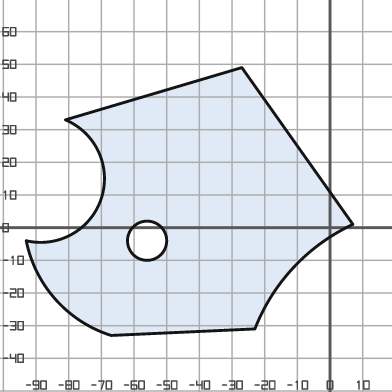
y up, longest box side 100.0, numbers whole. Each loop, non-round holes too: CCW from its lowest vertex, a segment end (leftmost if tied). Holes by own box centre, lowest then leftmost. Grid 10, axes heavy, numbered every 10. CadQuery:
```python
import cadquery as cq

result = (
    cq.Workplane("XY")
    .moveTo(-67.0, -33.0)
    .lineTo(-23.0, -31.0)
    .threePointArc((-11.0, -12.0), (7.0, 1.0))
    .lineTo(-27.0, 49.0)
    .lineTo(-81.0, 33.0)
    .threePointArc((-70.0, 9.0), (-93.0, -4.0))
    .threePointArc((-84.0, -22.0), (-67.0, -33.0))
    .close()
    .moveTo(-56.0, -4.0)
    .circle(6.0)
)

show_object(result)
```